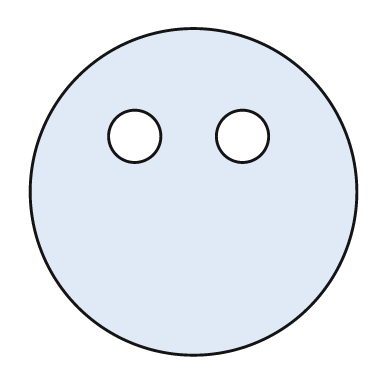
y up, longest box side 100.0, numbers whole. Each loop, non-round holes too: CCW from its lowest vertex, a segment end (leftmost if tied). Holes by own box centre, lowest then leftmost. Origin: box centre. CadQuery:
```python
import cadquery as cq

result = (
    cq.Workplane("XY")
    .moveTo(0.0, 0.0)
    .circle(50.0)
    .moveTo(-18.0, 17.0)
    .circle(8.0)
    .moveTo(15.0, 17.0)
    .circle(8.0)
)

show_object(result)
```